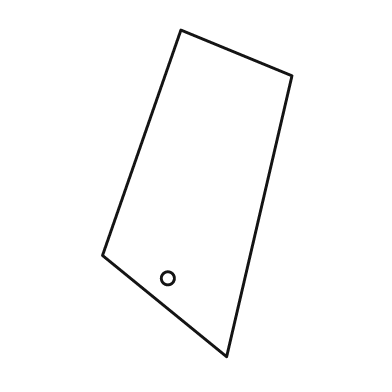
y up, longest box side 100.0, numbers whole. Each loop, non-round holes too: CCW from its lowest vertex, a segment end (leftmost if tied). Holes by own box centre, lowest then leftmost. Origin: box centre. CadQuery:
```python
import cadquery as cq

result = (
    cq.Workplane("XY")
    .moveTo(9.0, -50.0)
    .lineTo(29.0, 36.0)
    .lineTo(-5.0, 50.0)
    .lineTo(-29.0, -19.0)
    .close()
    .moveTo(-9.0, -26.0)
    .circle(2.0)
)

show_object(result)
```